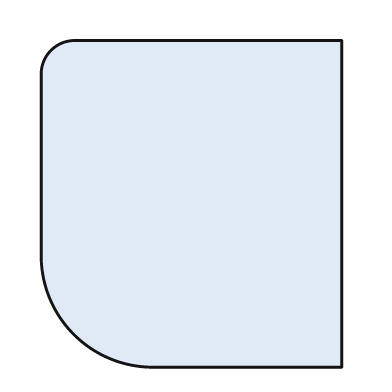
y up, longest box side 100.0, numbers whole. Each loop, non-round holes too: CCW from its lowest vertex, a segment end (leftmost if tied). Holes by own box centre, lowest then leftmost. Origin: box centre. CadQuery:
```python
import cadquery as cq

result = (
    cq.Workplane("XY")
    .moveTo(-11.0, -50.0)
    .lineTo(46.0, -50.0)
    .lineTo(46.0, 50.0)
    .lineTo(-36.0, 50.0)
    .threePointArc((-43.0, 47.0), (-46.0, 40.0))
    .lineTo(-46.0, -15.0)
    .threePointArc((-36.0, -40.0), (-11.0, -50.0))
    .close()
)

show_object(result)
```